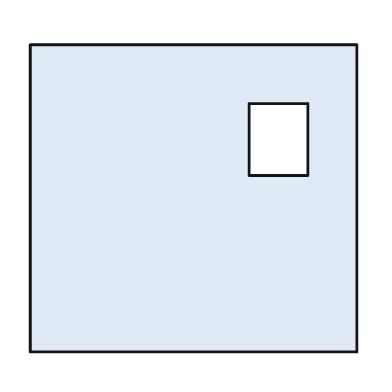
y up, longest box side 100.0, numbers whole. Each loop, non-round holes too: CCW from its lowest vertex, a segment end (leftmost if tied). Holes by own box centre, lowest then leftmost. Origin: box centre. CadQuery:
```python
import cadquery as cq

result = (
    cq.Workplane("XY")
    .moveTo(-50.0, -47.0)
    .lineTo(50.0, -47.0)
    .lineTo(50.0, 47.0)
    .lineTo(-50.0, 47.0)
    .close()
    .moveTo(17.0, 7.0)
    .lineTo(35.0, 7.0)
    .lineTo(35.0, 29.0)
    .lineTo(17.0, 29.0)
    .close()
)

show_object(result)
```